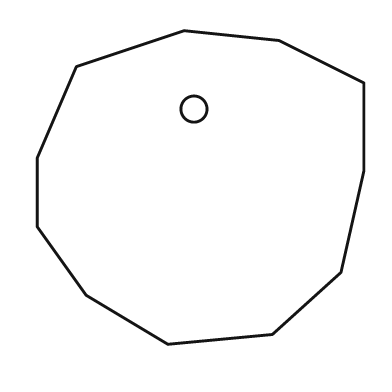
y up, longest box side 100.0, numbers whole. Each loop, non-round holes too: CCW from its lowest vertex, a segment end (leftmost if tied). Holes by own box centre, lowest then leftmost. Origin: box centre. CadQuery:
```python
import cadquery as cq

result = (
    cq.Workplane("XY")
    .moveTo(-10.0, -48.0)
    .lineTo(22.0, -45.0)
    .lineTo(43.0, -26.0)
    .lineTo(50.0, 5.0)
    .lineTo(50.0, 32.0)
    .lineTo(24.0, 45.0)
    .lineTo(-5.0, 48.0)
    .lineTo(-38.0, 37.0)
    .lineTo(-50.0, 9.0)
    .lineTo(-50.0, -12.0)
    .lineTo(-35.0, -33.0)
    .close()
    .moveTo(-2.0, 24.0)
    .circle(4.0)
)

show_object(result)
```